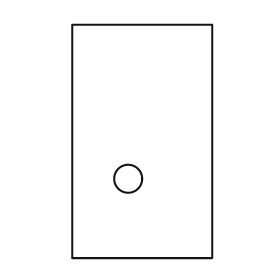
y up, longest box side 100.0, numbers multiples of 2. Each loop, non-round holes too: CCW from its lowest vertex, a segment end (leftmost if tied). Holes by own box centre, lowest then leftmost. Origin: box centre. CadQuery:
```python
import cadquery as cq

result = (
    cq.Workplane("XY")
    .moveTo(-30.0, -50.0)
    .lineTo(30.0, -50.0)
    .lineTo(30.0, 50.0)
    .lineTo(-30.0, 50.0)
    .close()
    .moveTo(-6.0, -16.0)
    .circle(6.0)
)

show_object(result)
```